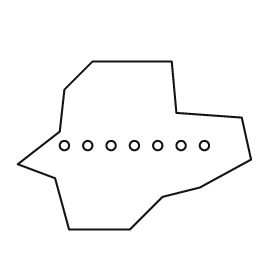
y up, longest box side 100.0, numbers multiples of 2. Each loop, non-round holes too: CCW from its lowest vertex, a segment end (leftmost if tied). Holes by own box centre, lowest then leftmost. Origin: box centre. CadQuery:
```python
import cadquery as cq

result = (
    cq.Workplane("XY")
    .moveTo(-28.0, -36.0)
    .lineTo(-2.0, -36.0)
    .lineTo(12.0, -22.0)
    .lineTo(28.0, -18.0)
    .lineTo(50.0, -6.0)
    .lineTo(46.0, 12.0)
    .lineTo(18.0, 14.0)
    .lineTo(16.0, 36.0)
    .lineTo(-18.0, 36.0)
    .lineTo(-30.0, 24.0)
    .lineTo(-32.0, 6.0)
    .lineTo(-50.0, -8.0)
    .lineTo(-34.0, -14.0)
    .close()
    .moveTo(-30.0, 0.0)
    .circle(2.0)
    .moveTo(-20.0, 0.0)
    .circle(2.0)
    .moveTo(-10.0, 0.0)
    .circle(2.0)
    .moveTo(0.0, 0.0)
    .circle(2.0)
    .moveTo(10.0, 0.0)
    .circle(2.0)
    .moveTo(20.0, 0.0)
    .circle(2.0)
    .moveTo(30.0, 0.0)
    .circle(2.0)
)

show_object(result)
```